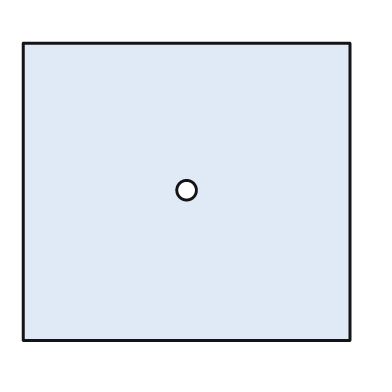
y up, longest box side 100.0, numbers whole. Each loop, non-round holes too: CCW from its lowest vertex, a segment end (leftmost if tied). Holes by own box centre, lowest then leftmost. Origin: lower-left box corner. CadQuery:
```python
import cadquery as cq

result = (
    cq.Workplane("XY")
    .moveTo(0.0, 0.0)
    .lineTo(100.0, 0.0)
    .lineTo(100.0, 91.0)
    .lineTo(0.0, 91.0)
    .close()
    .moveTo(50.0, 46.0)
    .circle(3.0)
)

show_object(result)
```